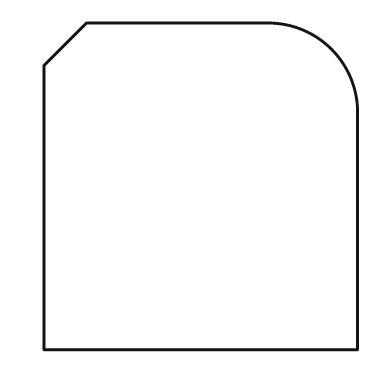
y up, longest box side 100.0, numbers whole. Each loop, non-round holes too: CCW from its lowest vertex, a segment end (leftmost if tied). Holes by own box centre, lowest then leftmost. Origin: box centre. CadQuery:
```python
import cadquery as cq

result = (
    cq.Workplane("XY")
    .moveTo(-48.0, -50.0)
    .lineTo(48.0, -50.0)
    .lineTo(48.0, 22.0)
    .threePointArc((40.0, 42.0), (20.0, 50.0))
    .lineTo(-35.0, 50.0)
    .lineTo(-48.0, 37.0)
    .close()
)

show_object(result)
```